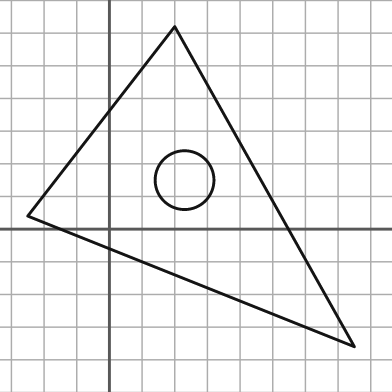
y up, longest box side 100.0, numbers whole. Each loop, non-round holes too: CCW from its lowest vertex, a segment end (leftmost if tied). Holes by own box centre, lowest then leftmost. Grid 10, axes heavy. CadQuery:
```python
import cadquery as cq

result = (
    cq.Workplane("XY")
    .moveTo(75.0, -36.0)
    .lineTo(20.0, 62.0)
    .lineTo(-25.0, 4.0)
    .close()
    .moveTo(23.0, 15.0)
    .circle(9.0)
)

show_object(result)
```